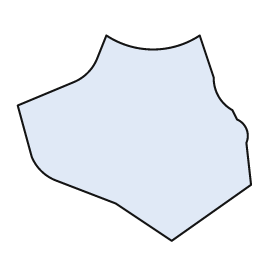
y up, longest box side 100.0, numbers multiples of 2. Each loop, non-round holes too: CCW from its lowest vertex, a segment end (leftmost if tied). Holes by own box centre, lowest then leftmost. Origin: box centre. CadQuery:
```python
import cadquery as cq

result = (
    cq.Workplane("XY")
    .moveTo(16.0, -44.0)
    .lineTo(50.0, -20.0)
    .lineTo(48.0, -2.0)
    .threePointArc((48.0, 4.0), (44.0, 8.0))
    .lineTo(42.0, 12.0)
    .threePointArc((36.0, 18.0), (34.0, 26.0))
    .lineTo(28.0, 44.0)
    .threePointArc((8.0, 38.0), (-12.0, 44.0))
    .lineTo(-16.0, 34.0)
    .threePointArc((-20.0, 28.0), (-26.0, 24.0))
    .lineTo(-50.0, 14.0)
    .lineTo(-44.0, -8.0)
    .threePointArc((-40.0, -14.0), (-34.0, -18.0))
    .lineTo(-8.0, -28.0)
    .close()
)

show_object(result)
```